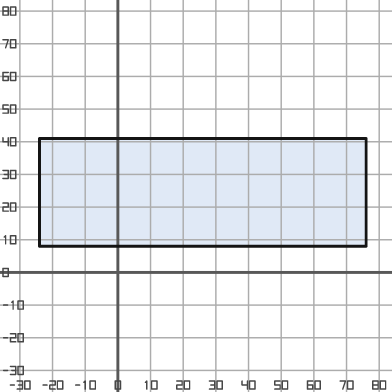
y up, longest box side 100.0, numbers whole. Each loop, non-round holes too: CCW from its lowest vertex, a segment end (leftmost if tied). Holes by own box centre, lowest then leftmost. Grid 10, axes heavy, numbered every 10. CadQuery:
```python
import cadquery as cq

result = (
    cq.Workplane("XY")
    .moveTo(-24.0, 8.0)
    .lineTo(76.0, 8.0)
    .lineTo(76.0, 41.0)
    .lineTo(-24.0, 41.0)
    .close()
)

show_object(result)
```